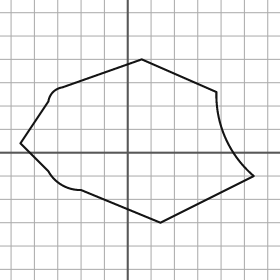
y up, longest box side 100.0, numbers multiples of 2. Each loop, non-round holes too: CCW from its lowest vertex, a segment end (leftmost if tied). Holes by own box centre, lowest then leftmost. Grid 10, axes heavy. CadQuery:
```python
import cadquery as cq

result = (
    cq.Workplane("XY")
    .moveTo(14.0, -30.0)
    .lineTo(54.0, -10.0)
    .threePointArc((42.0, 6.0), (38.0, 26.0))
    .lineTo(6.0, 40.0)
    .lineTo(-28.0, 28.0)
    .threePointArc((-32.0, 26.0), (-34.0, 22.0))
    .lineTo(-46.0, 4.0)
    .lineTo(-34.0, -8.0)
    .threePointArc((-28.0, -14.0), (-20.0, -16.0))
    .close()
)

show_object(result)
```